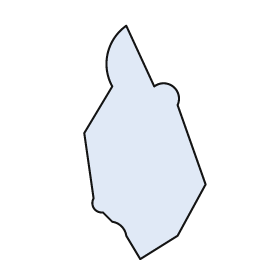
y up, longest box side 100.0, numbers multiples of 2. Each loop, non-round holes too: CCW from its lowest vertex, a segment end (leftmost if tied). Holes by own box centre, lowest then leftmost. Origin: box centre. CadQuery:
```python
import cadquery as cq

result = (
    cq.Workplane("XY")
    .moveTo(-2.0, -50.0)
    .lineTo(14.0, -40.0)
    .lineTo(26.0, -18.0)
    .lineTo(14.0, 16.0)
    .threePointArc((12.0, 24.0), (4.0, 24.0))
    .lineTo(-8.0, 50.0)
    .threePointArc((-16.0, 38.0), (-14.0, 24.0))
    .lineTo(-26.0, 4.0)
    .lineTo(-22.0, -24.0)
    .threePointArc((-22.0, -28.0), (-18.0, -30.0))
    .lineTo(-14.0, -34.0)
    .threePointArc((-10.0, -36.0), (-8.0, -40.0))
    .close()
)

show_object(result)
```